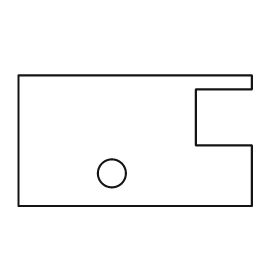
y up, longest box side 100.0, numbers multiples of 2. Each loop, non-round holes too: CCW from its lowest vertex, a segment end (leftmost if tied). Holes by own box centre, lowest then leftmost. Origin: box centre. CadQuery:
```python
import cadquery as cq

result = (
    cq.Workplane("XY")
    .moveTo(-50.0, -28.0)
    .lineTo(50.0, -28.0)
    .lineTo(50.0, -2.0)
    .lineTo(26.0, -2.0)
    .lineTo(26.0, 22.0)
    .lineTo(50.0, 22.0)
    .lineTo(50.0, 28.0)
    .lineTo(-50.0, 28.0)
    .close()
    .moveTo(-10.0, -14.0)
    .circle(6.0)
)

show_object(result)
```